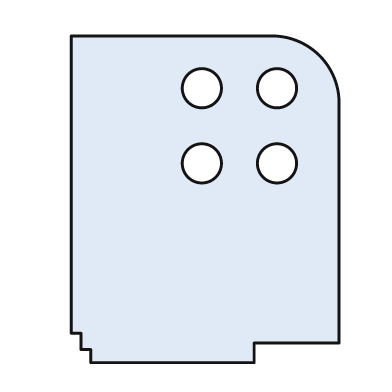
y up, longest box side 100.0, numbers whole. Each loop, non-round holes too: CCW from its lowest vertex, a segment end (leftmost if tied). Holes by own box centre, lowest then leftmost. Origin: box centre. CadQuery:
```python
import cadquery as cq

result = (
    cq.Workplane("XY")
    .moveTo(-35.0, -50.0)
    .lineTo(15.0, -50.0)
    .lineTo(15.0, -44.0)
    .lineTo(41.0, -44.0)
    .lineTo(41.0, 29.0)
    .threePointArc((35.0, 44.0), (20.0, 50.0))
    .lineTo(-41.0, 50.0)
    .lineTo(-41.0, -41.0)
    .lineTo(-38.0, -41.0)
    .lineTo(-38.0, -46.0)
    .lineTo(-35.0, -46.0)
    .close()
    .moveTo(-1.0, 11.0)
    .circle(6.0)
    .moveTo(22.0, 11.0)
    .circle(6.0)
    .moveTo(-1.0, 34.0)
    .circle(6.0)
    .moveTo(22.0, 34.0)
    .circle(6.0)
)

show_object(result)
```